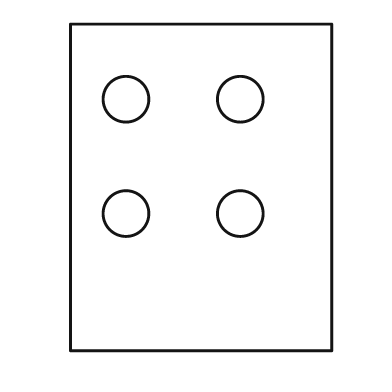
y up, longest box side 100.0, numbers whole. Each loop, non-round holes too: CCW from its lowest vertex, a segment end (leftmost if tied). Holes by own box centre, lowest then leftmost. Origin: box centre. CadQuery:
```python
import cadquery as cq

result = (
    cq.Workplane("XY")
    .moveTo(-40.0, -50.0)
    .lineTo(40.0, -50.0)
    .lineTo(40.0, 50.0)
    .lineTo(-40.0, 50.0)
    .close()
    .moveTo(-23.0, -8.0)
    .circle(7.0)
    .moveTo(12.0, -8.0)
    .circle(7.0)
    .moveTo(-23.0, 27.0)
    .circle(7.0)
    .moveTo(12.0, 27.0)
    .circle(7.0)
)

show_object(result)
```